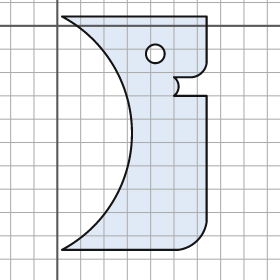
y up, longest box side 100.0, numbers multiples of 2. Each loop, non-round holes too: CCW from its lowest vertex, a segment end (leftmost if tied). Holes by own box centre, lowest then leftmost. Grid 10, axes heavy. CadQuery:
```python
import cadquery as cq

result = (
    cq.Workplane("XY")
    .moveTo(2.0, -96.0)
    .lineTo(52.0, -96.0)
    .threePointArc((60.0, -92.0), (64.0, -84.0))
    .lineTo(64.0, -30.0)
    .lineTo(50.0, -30.0)
    .threePointArc((52.0, -26.0), (50.0, -22.0))
    .lineTo(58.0, -22.0)
    .threePointArc((62.0, -20.0), (64.0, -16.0))
    .lineTo(64.0, 4.0)
    .lineTo(2.0, 4.0)
    .threePointArc((32.0, -46.0), (2.0, -96.0))
    .close()
    .moveTo(42.0, -12.0)
    .circle(4.0)
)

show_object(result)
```